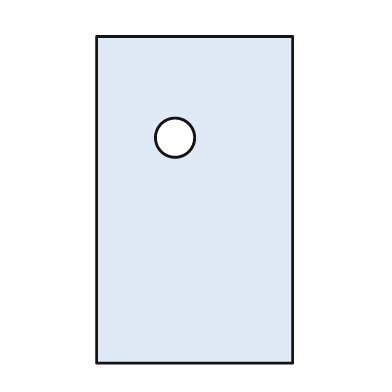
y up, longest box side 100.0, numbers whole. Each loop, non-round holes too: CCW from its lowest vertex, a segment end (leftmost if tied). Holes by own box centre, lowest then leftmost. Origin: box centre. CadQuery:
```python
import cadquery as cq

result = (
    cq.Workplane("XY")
    .moveTo(-30.0, -50.0)
    .lineTo(30.0, -50.0)
    .lineTo(30.0, 50.0)
    .lineTo(-30.0, 50.0)
    .close()
    .moveTo(-6.0, 19.0)
    .circle(6.0)
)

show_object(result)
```